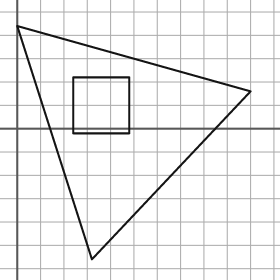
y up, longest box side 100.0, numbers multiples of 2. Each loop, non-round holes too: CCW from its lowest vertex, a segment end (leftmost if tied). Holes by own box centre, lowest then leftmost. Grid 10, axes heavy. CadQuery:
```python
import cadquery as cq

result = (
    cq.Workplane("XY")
    .moveTo(32.0, -56.0)
    .lineTo(100.0, 16.0)
    .lineTo(0.0, 44.0)
    .close()
    .moveTo(24.0, -2.0)
    .lineTo(48.0, -2.0)
    .lineTo(48.0, 22.0)
    .lineTo(24.0, 22.0)
    .close()
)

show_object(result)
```